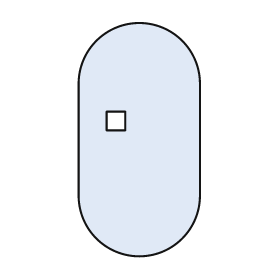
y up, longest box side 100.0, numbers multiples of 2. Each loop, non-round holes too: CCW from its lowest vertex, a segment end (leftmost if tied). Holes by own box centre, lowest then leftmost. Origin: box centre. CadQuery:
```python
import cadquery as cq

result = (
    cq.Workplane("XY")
    .moveTo(-26.0, -24.0)
    .threePointArc((0.0, -50.0), (26.0, -24.0))
    .lineTo(26.0, 24.0)
    .threePointArc((0.0, 50.0), (-26.0, 24.0))
    .close()
    .moveTo(-14.0, 4.0)
    .lineTo(-6.0, 4.0)
    .lineTo(-6.0, 12.0)
    .lineTo(-14.0, 12.0)
    .close()
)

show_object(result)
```